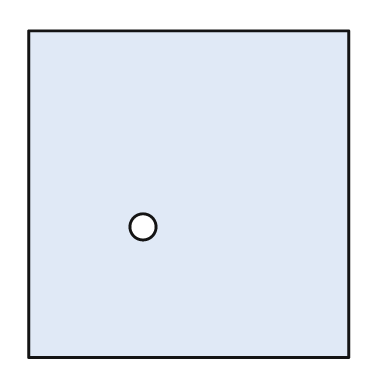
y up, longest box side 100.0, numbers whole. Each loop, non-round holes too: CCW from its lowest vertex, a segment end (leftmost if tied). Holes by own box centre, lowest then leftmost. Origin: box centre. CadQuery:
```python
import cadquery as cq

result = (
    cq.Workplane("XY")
    .moveTo(-49.0, -50.0)
    .lineTo(49.0, -50.0)
    .lineTo(49.0, 50.0)
    .lineTo(-49.0, 50.0)
    .close()
    .moveTo(-14.0, -10.0)
    .circle(4.0)
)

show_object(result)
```